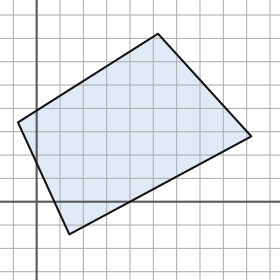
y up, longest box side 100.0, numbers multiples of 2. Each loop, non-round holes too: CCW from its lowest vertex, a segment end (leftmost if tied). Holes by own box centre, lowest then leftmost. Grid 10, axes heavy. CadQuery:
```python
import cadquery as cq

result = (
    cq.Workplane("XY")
    .moveTo(14.0, -14.0)
    .lineTo(92.0, 28.0)
    .lineTo(52.0, 72.0)
    .lineTo(-8.0, 34.0)
    .close()
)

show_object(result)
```